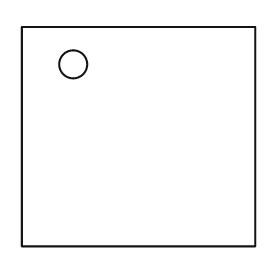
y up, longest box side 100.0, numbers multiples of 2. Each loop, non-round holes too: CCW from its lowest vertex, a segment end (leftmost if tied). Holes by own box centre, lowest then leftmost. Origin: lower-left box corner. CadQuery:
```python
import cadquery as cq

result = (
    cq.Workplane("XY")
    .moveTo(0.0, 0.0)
    .lineTo(100.0, 0.0)
    .lineTo(100.0, 94.0)
    .lineTo(0.0, 94.0)
    .close()
    .moveTo(22.0, 78.0)
    .circle(6.0)
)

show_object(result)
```